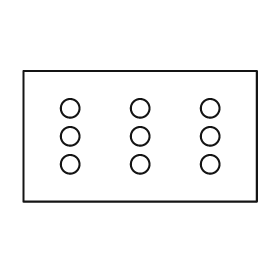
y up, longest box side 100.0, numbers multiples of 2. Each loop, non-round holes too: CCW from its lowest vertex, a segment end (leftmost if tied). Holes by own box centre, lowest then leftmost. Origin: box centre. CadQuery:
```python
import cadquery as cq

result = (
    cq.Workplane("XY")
    .moveTo(-50.0, -28.0)
    .lineTo(50.0, -28.0)
    .lineTo(50.0, 28.0)
    .lineTo(-50.0, 28.0)
    .close()
    .moveTo(-30.0, -12.0)
    .circle(4.0)
    .moveTo(0.0, -12.0)
    .circle(4.0)
    .moveTo(30.0, -12.0)
    .circle(4.0)
    .moveTo(-30.0, 0.0)
    .circle(4.0)
    .moveTo(0.0, 0.0)
    .circle(4.0)
    .moveTo(30.0, 0.0)
    .circle(4.0)
    .moveTo(-30.0, 12.0)
    .circle(4.0)
    .moveTo(0.0, 12.0)
    .circle(4.0)
    .moveTo(30.0, 12.0)
    .circle(4.0)
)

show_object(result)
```